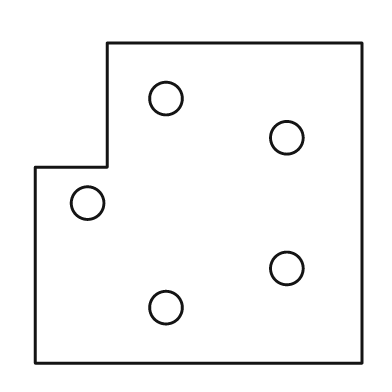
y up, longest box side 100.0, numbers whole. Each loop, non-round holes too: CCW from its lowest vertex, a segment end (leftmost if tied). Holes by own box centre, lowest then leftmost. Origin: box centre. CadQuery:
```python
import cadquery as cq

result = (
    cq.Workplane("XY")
    .moveTo(-50.0, -49.0)
    .lineTo(50.0, -49.0)
    .lineTo(50.0, 49.0)
    .lineTo(-28.0, 49.0)
    .lineTo(-28.0, 11.0)
    .lineTo(-50.0, 11.0)
    .close()
    .moveTo(-10.0, -32.0)
    .circle(5.0)
    .moveTo(27.0, -20.0)
    .circle(5.0)
    .moveTo(-34.0, 0.0)
    .circle(5.0)
    .moveTo(27.0, 20.0)
    .circle(5.0)
    .moveTo(-10.0, 32.0)
    .circle(5.0)
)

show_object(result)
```